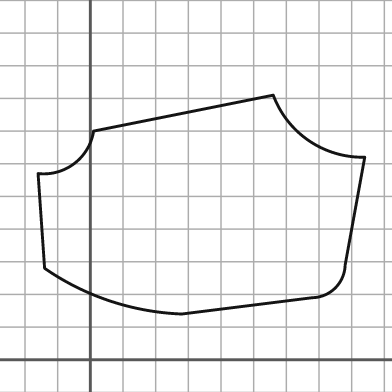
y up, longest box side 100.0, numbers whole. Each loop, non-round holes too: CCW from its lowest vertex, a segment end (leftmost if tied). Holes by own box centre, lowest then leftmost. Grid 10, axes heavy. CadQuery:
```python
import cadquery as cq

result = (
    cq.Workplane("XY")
    .moveTo(28.0, 14.0)
    .lineTo(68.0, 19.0)
    .threePointArc((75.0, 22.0), (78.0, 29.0))
    .lineTo(84.0, 62.0)
    .threePointArc((67.0, 67.0), (56.0, 81.0))
    .lineTo(1.0, 70.0)
    .threePointArc((-5.0, 60.0), (-16.0, 57.0))
    .lineTo(-14.0, 28.0)
    .threePointArc((6.0, 18.0), (28.0, 14.0))
    .close()
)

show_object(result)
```